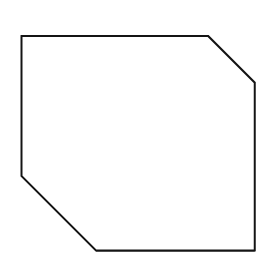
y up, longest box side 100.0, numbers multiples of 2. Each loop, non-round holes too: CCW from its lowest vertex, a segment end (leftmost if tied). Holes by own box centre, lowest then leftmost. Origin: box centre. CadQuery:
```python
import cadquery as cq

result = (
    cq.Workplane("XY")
    .moveTo(-18.0, -46.0)
    .lineTo(50.0, -46.0)
    .lineTo(50.0, 26.0)
    .lineTo(30.0, 46.0)
    .lineTo(-50.0, 46.0)
    .lineTo(-50.0, -14.0)
    .close()
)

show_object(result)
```